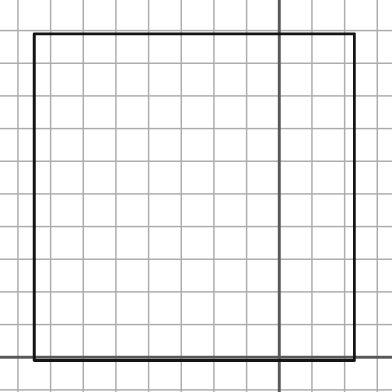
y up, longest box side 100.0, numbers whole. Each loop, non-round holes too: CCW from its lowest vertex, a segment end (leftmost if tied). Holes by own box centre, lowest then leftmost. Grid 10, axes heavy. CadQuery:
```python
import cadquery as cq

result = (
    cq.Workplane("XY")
    .moveTo(-75.0, -1.0)
    .lineTo(23.0, -1.0)
    .lineTo(23.0, 99.0)
    .lineTo(-75.0, 99.0)
    .close()
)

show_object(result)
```